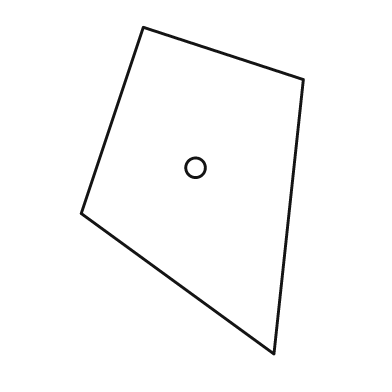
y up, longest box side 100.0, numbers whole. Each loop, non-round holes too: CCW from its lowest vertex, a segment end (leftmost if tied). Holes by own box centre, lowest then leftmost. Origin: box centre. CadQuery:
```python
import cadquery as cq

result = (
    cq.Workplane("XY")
    .moveTo(25.0, -50.0)
    .lineTo(34.0, 34.0)
    .lineTo(-15.0, 50.0)
    .lineTo(-34.0, -7.0)
    .close()
    .moveTo(1.0, 7.0)
    .circle(3.0)
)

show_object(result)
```